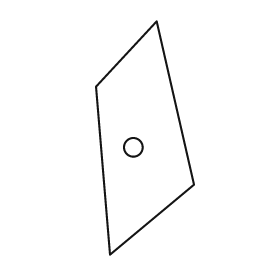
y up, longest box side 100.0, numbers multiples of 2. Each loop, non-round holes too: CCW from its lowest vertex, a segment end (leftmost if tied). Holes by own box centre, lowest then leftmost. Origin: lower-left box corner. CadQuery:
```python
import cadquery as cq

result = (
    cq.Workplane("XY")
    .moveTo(6.0, 0.0)
    .lineTo(42.0, 30.0)
    .lineTo(26.0, 100.0)
    .lineTo(0.0, 72.0)
    .close()
    .moveTo(16.0, 46.0)
    .circle(4.0)
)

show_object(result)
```